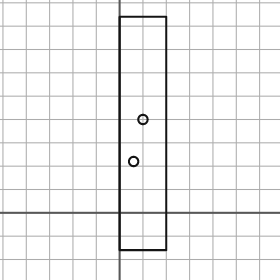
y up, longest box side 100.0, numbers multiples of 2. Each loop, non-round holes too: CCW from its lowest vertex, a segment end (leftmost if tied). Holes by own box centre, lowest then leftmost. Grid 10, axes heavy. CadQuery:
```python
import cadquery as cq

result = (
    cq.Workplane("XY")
    .moveTo(0.0, -16.0)
    .lineTo(20.0, -16.0)
    .lineTo(20.0, 84.0)
    .lineTo(0.0, 84.0)
    .close()
    .moveTo(6.0, 22.0)
    .circle(2.0)
    .moveTo(10.0, 40.0)
    .circle(2.0)
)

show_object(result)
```